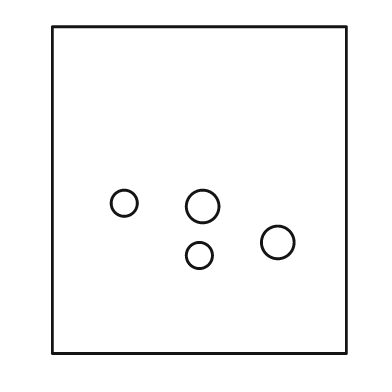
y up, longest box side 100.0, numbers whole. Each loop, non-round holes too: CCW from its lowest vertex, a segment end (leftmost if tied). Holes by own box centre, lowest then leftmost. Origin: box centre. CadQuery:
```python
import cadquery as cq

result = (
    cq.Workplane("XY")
    .moveTo(-45.0, -50.0)
    .lineTo(45.0, -50.0)
    .lineTo(45.0, 50.0)
    .lineTo(-45.0, 50.0)
    .close()
    .moveTo(0.0, -20.0)
    .circle(4.0)
    .moveTo(24.0, -16.0)
    .circle(5.0)
    .moveTo(1.0, -5.0)
    .circle(5.0)
    .moveTo(-23.0, -4.0)
    .circle(4.0)
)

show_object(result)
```